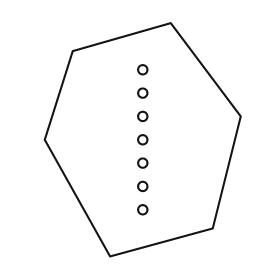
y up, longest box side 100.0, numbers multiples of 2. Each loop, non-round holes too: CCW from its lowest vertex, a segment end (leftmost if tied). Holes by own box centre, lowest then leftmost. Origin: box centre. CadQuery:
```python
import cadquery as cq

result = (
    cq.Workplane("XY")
    .moveTo(-14.0, -50.0)
    .lineTo(30.0, -38.0)
    .lineTo(42.0, 10.0)
    .lineTo(12.0, 50.0)
    .lineTo(-30.0, 38.0)
    .lineTo(-42.0, 0.0)
    .close()
    .moveTo(0.0, -30.0)
    .circle(2.0)
    .moveTo(0.0, -20.0)
    .circle(2.0)
    .moveTo(0.0, -10.0)
    .circle(2.0)
    .moveTo(0.0, 0.0)
    .circle(2.0)
    .moveTo(0.0, 10.0)
    .circle(2.0)
    .moveTo(0.0, 20.0)
    .circle(2.0)
    .moveTo(0.0, 30.0)
    .circle(2.0)
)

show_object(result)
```